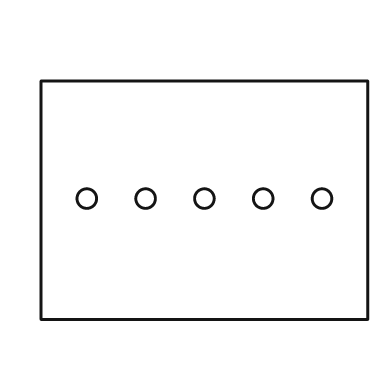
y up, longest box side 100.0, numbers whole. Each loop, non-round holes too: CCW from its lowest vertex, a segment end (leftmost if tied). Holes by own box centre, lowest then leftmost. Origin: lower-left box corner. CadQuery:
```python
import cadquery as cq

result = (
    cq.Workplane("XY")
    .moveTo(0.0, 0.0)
    .lineTo(100.0, 0.0)
    .lineTo(100.0, 73.0)
    .lineTo(0.0, 73.0)
    .close()
    .moveTo(14.0, 37.0)
    .circle(3.0)
    .moveTo(32.0, 37.0)
    .circle(3.0)
    .moveTo(50.0, 37.0)
    .circle(3.0)
    .moveTo(68.0, 37.0)
    .circle(3.0)
    .moveTo(86.0, 37.0)
    .circle(3.0)
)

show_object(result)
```